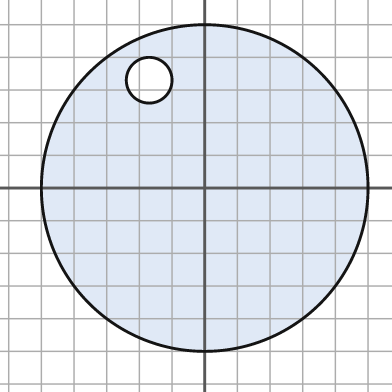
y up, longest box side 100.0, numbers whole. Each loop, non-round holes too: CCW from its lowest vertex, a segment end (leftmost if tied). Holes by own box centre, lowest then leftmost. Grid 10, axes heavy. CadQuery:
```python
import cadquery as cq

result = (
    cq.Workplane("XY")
    .moveTo(0.0, 0.0)
    .circle(50.0)
    .moveTo(-17.0, 33.0)
    .circle(7.0)
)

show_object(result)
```